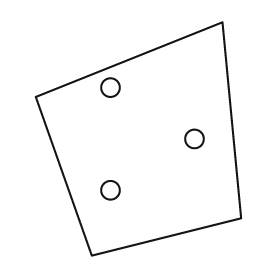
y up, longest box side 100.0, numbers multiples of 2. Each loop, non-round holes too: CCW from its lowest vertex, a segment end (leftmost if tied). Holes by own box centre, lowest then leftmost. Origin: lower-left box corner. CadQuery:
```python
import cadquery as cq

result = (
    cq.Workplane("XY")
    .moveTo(24.0, 0.0)
    .lineTo(88.0, 16.0)
    .lineTo(80.0, 100.0)
    .lineTo(0.0, 68.0)
    .close()
    .moveTo(32.0, 28.0)
    .circle(4.0)
    .moveTo(68.0, 50.0)
    .circle(4.0)
    .moveTo(32.0, 72.0)
    .circle(4.0)
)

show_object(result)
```